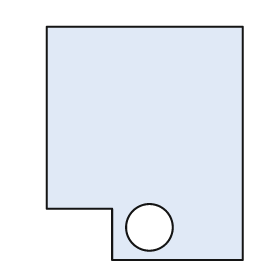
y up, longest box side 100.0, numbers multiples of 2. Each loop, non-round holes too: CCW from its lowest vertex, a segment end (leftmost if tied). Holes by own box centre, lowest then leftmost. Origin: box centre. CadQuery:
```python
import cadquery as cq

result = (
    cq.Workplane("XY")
    .moveTo(-14.0, -50.0)
    .lineTo(42.0, -50.0)
    .lineTo(42.0, 50.0)
    .lineTo(-42.0, 50.0)
    .lineTo(-42.0, -28.0)
    .lineTo(-14.0, -28.0)
    .close()
    .moveTo(2.0, -36.0)
    .circle(10.0)
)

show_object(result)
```